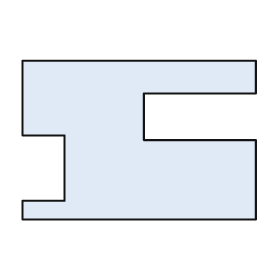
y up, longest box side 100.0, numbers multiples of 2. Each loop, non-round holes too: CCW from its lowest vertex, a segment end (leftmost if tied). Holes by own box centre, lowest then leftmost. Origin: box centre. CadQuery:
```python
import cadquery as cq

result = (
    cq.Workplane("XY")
    .moveTo(-50.0, -34.0)
    .lineTo(50.0, -34.0)
    .lineTo(50.0, 0.0)
    .lineTo(2.0, 0.0)
    .lineTo(2.0, 20.0)
    .lineTo(50.0, 20.0)
    .lineTo(50.0, 34.0)
    .lineTo(-50.0, 34.0)
    .lineTo(-50.0, 2.0)
    .lineTo(-32.0, 2.0)
    .lineTo(-32.0, -26.0)
    .lineTo(-50.0, -26.0)
    .close()
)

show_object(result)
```